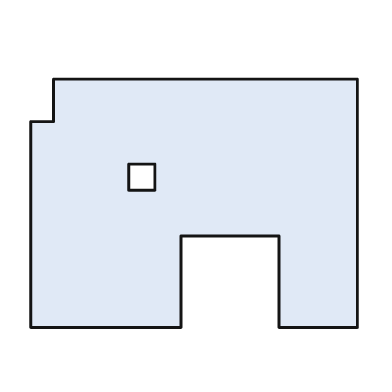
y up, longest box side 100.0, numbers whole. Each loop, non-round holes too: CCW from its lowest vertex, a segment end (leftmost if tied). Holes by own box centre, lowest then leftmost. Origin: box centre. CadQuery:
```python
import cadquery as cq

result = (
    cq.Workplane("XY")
    .moveTo(-50.0, -38.0)
    .lineTo(-4.0, -38.0)
    .lineTo(-4.0, -10.0)
    .lineTo(26.0, -10.0)
    .lineTo(26.0, -38.0)
    .lineTo(50.0, -38.0)
    .lineTo(50.0, 38.0)
    .lineTo(-43.0, 38.0)
    .lineTo(-43.0, 25.0)
    .lineTo(-50.0, 25.0)
    .close()
    .moveTo(-20.0, 4.0)
    .lineTo(-12.0, 4.0)
    .lineTo(-12.0, 12.0)
    .lineTo(-20.0, 12.0)
    .close()
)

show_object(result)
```